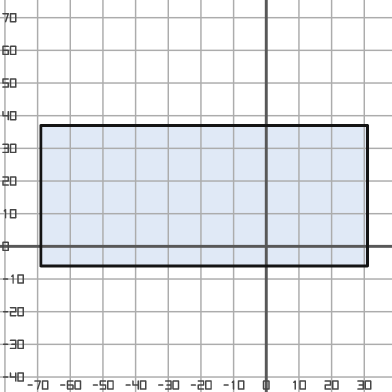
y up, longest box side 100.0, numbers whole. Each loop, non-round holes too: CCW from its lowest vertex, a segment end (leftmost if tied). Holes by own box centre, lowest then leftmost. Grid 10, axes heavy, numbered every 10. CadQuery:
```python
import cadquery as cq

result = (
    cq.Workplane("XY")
    .moveTo(-69.0, -6.0)
    .lineTo(31.0, -6.0)
    .lineTo(31.0, 37.0)
    .lineTo(-69.0, 37.0)
    .close()
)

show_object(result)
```